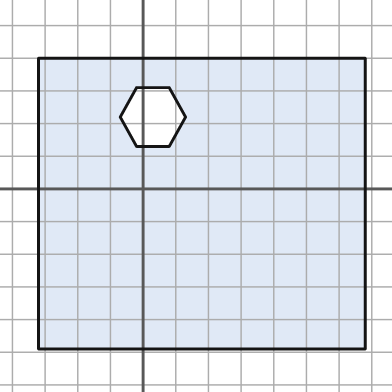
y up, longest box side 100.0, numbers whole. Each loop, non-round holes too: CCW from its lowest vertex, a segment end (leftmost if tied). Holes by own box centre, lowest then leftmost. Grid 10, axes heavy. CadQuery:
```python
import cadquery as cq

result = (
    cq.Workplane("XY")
    .moveTo(-32.0, -49.0)
    .lineTo(68.0, -49.0)
    .lineTo(68.0, 40.0)
    .lineTo(-32.0, 40.0)
    .close()
    .moveTo(-2.0, 13.0)
    .lineTo(8.0, 13.0)
    .lineTo(13.0, 22.0)
    .lineTo(8.0, 31.0)
    .lineTo(-2.0, 31.0)
    .lineTo(-7.0, 22.0)
    .close()
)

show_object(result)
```